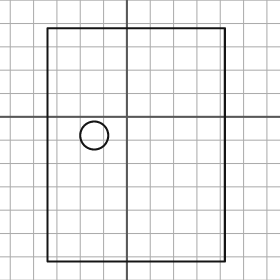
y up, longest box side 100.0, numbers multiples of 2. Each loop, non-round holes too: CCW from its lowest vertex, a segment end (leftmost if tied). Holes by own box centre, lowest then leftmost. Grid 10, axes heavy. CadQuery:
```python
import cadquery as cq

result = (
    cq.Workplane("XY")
    .moveTo(-34.0, -62.0)
    .lineTo(42.0, -62.0)
    .lineTo(42.0, 38.0)
    .lineTo(-34.0, 38.0)
    .close()
    .moveTo(-14.0, -8.0)
    .circle(6.0)
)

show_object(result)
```